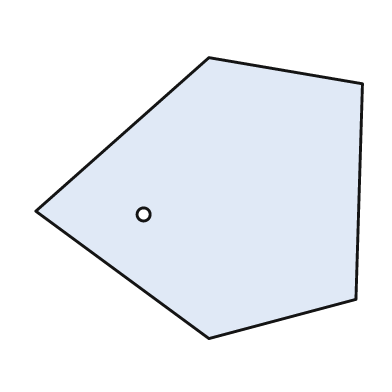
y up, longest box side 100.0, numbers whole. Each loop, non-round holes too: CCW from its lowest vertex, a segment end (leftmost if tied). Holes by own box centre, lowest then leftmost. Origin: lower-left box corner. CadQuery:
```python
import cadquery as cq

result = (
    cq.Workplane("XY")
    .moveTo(53.0, 0.0)
    .lineTo(98.0, 12.0)
    .lineTo(100.0, 78.0)
    .lineTo(53.0, 86.0)
    .lineTo(0.0, 39.0)
    .close()
    .moveTo(33.0, 38.0)
    .circle(2.0)
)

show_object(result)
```